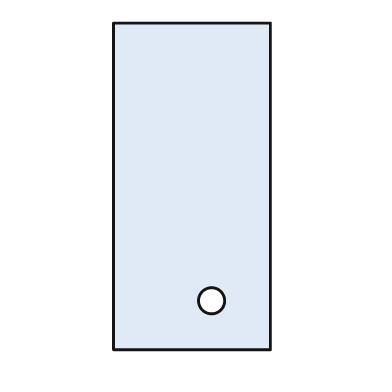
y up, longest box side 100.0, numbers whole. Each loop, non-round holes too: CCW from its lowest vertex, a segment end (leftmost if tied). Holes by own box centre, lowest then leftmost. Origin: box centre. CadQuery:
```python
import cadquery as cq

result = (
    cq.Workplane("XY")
    .moveTo(-24.0, -50.0)
    .lineTo(24.0, -50.0)
    .lineTo(24.0, 50.0)
    .lineTo(-24.0, 50.0)
    .close()
    .moveTo(6.0, -35.0)
    .circle(4.0)
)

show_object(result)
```